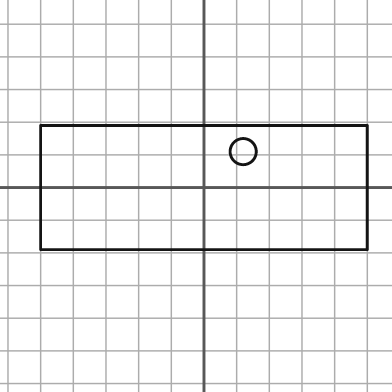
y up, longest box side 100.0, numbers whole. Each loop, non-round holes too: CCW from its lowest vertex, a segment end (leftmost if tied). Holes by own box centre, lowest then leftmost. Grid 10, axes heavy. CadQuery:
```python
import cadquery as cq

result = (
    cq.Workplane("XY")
    .moveTo(-50.0, -19.0)
    .lineTo(50.0, -19.0)
    .lineTo(50.0, 19.0)
    .lineTo(-50.0, 19.0)
    .close()
    .moveTo(12.0, 11.0)
    .circle(4.0)
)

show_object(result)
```